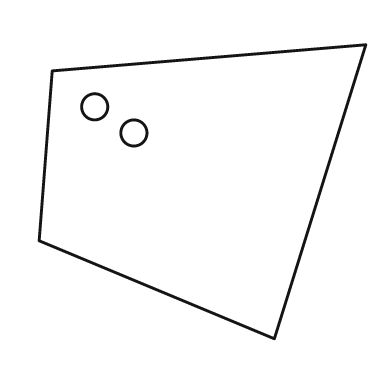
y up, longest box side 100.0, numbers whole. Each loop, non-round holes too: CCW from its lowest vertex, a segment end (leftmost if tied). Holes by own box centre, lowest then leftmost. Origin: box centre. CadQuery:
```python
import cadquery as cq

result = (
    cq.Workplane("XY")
    .moveTo(22.0, -45.0)
    .lineTo(50.0, 45.0)
    .lineTo(-46.0, 37.0)
    .lineTo(-50.0, -15.0)
    .close()
    .moveTo(-21.0, 18.0)
    .circle(4.0)
    .moveTo(-33.0, 26.0)
    .circle(4.0)
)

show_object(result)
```